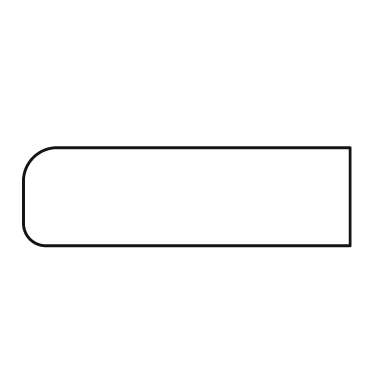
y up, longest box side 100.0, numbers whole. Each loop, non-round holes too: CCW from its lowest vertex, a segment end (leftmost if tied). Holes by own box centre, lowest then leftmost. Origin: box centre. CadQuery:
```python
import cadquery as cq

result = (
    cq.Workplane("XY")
    .moveTo(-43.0, -15.0)
    .lineTo(50.0, -15.0)
    .lineTo(50.0, 15.0)
    .lineTo(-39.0, 15.0)
    .threePointArc((-47.0, 12.0), (-50.0, 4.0))
    .lineTo(-50.0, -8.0)
    .threePointArc((-48.0, -13.0), (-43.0, -15.0))
    .close()
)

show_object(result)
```